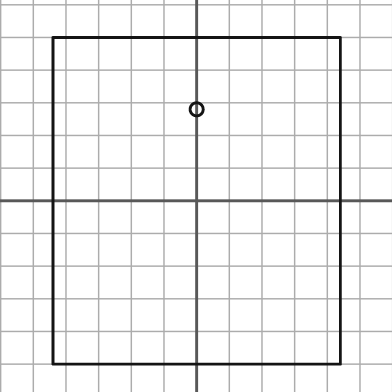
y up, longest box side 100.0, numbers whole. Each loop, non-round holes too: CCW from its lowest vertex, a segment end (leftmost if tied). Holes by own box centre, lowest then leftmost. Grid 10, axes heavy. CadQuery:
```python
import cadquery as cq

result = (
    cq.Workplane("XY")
    .moveTo(-44.0, -50.0)
    .lineTo(44.0, -50.0)
    .lineTo(44.0, 50.0)
    .lineTo(-44.0, 50.0)
    .close()
    .moveTo(0.0, 28.0)
    .circle(2.0)
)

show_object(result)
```